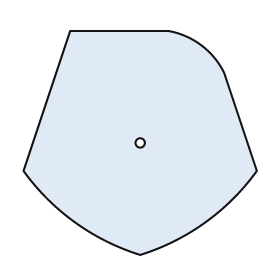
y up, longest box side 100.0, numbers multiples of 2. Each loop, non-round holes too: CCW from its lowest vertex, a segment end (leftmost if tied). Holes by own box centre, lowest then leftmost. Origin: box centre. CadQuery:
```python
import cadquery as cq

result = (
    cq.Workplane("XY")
    .moveTo(0.0, -48.0)
    .threePointArc((28.0, -34.0), (50.0, -12.0))
    .lineTo(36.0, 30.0)
    .threePointArc((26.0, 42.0), (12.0, 48.0))
    .lineTo(-30.0, 48.0)
    .lineTo(-50.0, -12.0)
    .threePointArc((-28.0, -34.0), (0.0, -48.0))
    .close()
    .moveTo(0.0, 0.0)
    .circle(2.0)
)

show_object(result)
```